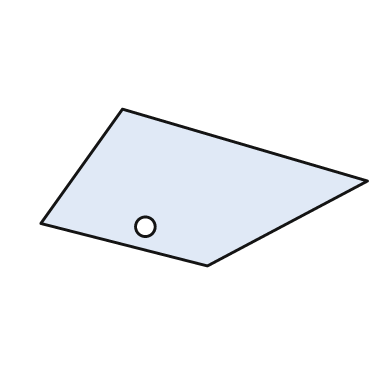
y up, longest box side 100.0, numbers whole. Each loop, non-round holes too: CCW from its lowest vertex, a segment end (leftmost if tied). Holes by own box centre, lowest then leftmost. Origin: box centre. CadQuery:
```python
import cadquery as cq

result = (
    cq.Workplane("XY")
    .moveTo(1.0, -24.0)
    .lineTo(50.0, 2.0)
    .lineTo(-25.0, 24.0)
    .lineTo(-50.0, -11.0)
    .close()
    .moveTo(-18.0, -12.0)
    .circle(3.0)
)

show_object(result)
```